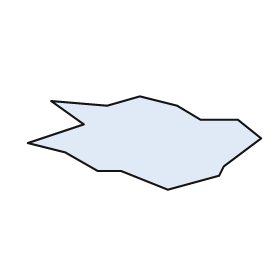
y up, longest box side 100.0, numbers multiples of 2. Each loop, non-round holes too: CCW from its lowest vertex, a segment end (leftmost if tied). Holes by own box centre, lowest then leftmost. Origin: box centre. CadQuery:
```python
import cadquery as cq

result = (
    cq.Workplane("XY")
    .moveTo(10.0, -20.0)
    .lineTo(32.0, -14.0)
    .lineTo(34.0, -10.0)
    .lineTo(50.0, 2.0)
    .lineTo(40.0, 10.0)
    .lineTo(24.0, 10.0)
    .lineTo(14.0, 16.0)
    .lineTo(-2.0, 20.0)
    .lineTo(-16.0, 16.0)
    .lineTo(-40.0, 18.0)
    .lineTo(-26.0, 8.0)
    .lineTo(-50.0, 0.0)
    .lineTo(-34.0, -4.0)
    .lineTo(-20.0, -12.0)
    .lineTo(-10.0, -12.0)
    .close()
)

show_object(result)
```